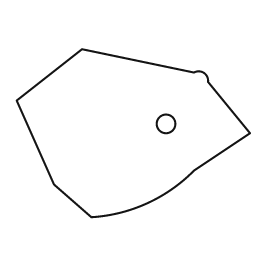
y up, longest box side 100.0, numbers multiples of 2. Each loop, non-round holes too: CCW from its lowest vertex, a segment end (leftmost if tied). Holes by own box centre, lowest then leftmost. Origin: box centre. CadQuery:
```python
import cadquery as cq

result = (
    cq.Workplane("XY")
    .moveTo(-18.0, -36.0)
    .threePointArc((6.0, -30.0), (26.0, -16.0))
    .lineTo(50.0, 0.0)
    .lineTo(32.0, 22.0)
    .threePointArc((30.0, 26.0), (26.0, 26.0))
    .lineTo(-22.0, 36.0)
    .lineTo(-50.0, 14.0)
    .lineTo(-34.0, -22.0)
    .close()
    .moveTo(14.0, 4.0)
    .circle(4.0)
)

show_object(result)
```